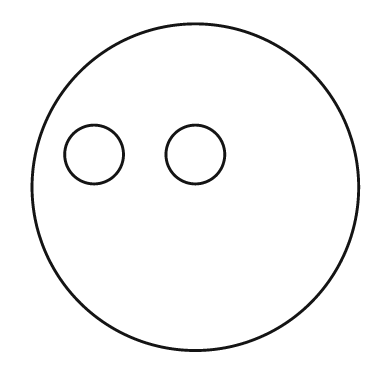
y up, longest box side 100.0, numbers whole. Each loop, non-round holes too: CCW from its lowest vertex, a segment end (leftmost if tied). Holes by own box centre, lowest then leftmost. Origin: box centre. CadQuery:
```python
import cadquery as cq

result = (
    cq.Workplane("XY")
    .moveTo(0.0, 0.0)
    .circle(50.0)
    .moveTo(-31.0, 10.0)
    .circle(9.0)
    .moveTo(0.0, 10.0)
    .circle(9.0)
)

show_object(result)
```